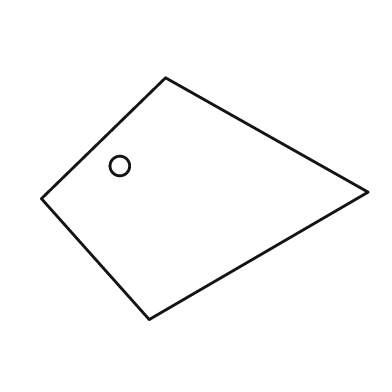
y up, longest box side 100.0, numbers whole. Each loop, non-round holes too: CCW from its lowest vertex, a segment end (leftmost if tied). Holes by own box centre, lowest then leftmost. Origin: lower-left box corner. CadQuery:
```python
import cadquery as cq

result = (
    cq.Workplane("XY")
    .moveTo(33.0, 0.0)
    .lineTo(100.0, 39.0)
    .lineTo(38.0, 74.0)
    .lineTo(0.0, 37.0)
    .close()
    .moveTo(24.0, 47.0)
    .circle(3.0)
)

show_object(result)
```